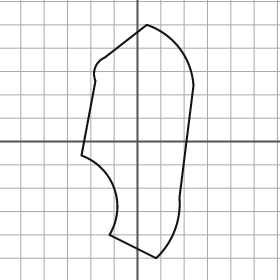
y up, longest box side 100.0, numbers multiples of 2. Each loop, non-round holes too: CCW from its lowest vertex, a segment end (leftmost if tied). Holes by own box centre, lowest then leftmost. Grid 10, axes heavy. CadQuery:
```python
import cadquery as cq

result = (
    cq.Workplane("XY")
    .moveTo(8.0, -50.0)
    .threePointArc((16.0, -38.0), (18.0, -24.0))
    .lineTo(24.0, 24.0)
    .threePointArc((18.0, 40.0), (4.0, 50.0))
    .lineTo(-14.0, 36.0)
    .threePointArc((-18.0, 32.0), (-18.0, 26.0))
    .lineTo(-24.0, -6.0)
    .threePointArc((-10.0, -20.0), (-12.0, -40.0))
    .close()
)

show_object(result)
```